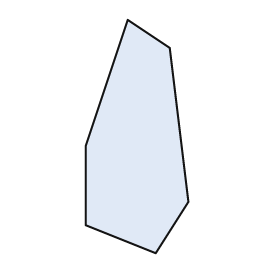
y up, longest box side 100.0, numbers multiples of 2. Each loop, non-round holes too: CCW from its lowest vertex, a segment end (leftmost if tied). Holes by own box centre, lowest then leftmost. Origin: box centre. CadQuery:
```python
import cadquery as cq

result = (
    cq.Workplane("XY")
    .moveTo(8.0, -50.0)
    .lineTo(22.0, -28.0)
    .lineTo(14.0, 38.0)
    .lineTo(-4.0, 50.0)
    .lineTo(-22.0, -4.0)
    .lineTo(-22.0, -38.0)
    .close()
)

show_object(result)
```